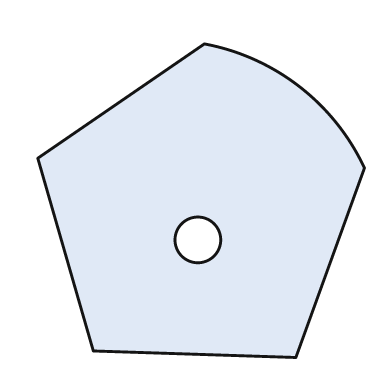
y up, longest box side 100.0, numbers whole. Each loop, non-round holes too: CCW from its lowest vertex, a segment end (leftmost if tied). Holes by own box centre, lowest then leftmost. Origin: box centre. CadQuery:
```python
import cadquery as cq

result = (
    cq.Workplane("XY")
    .moveTo(29.0, -48.0)
    .lineTo(50.0, 10.0)
    .threePointArc((30.0, 35.0), (1.0, 48.0))
    .lineTo(-50.0, 13.0)
    .lineTo(-33.0, -46.0)
    .close()
    .moveTo(-1.0, -12.0)
    .circle(7.0)
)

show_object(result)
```